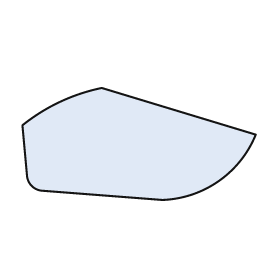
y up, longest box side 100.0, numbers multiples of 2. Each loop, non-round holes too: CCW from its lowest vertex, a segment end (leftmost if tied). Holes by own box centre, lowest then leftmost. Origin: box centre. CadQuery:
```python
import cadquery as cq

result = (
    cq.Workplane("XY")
    .moveTo(10.0, -24.0)
    .threePointArc((34.0, -16.0), (50.0, 4.0))
    .lineTo(-16.0, 24.0)
    .threePointArc((-34.0, 18.0), (-50.0, 8.0))
    .lineTo(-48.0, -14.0)
    .threePointArc((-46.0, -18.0), (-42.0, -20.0))
    .close()
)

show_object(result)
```